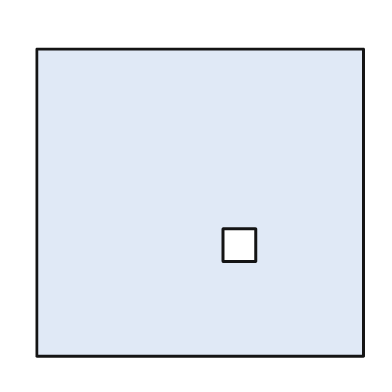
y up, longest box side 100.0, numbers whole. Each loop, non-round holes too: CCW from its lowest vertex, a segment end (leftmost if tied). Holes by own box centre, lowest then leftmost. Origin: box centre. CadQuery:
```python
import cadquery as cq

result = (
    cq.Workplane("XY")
    .moveTo(-50.0, -47.0)
    .lineTo(50.0, -47.0)
    .lineTo(50.0, 47.0)
    .lineTo(-50.0, 47.0)
    .close()
    .moveTo(7.0, -18.0)
    .lineTo(17.0, -18.0)
    .lineTo(17.0, -8.0)
    .lineTo(7.0, -8.0)
    .close()
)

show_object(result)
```